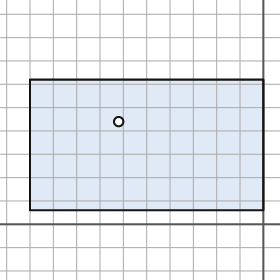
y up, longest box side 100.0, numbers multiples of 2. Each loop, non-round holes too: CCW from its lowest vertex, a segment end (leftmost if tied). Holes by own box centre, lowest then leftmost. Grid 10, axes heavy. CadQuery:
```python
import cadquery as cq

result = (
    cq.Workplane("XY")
    .moveTo(-100.0, 6.0)
    .lineTo(0.0, 6.0)
    .lineTo(0.0, 62.0)
    .lineTo(-100.0, 62.0)
    .close()
    .moveTo(-62.0, 44.0)
    .circle(2.0)
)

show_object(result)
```